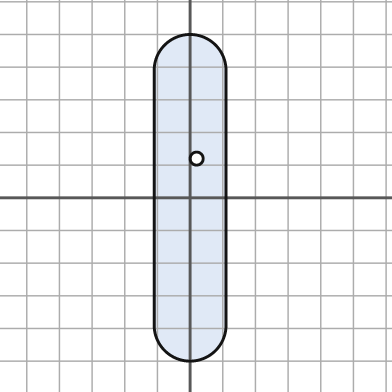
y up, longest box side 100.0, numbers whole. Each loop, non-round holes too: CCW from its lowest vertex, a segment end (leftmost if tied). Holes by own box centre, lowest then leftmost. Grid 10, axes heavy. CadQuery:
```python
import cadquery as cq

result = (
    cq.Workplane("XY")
    .moveTo(-11.0, -39.0)
    .threePointArc((0.0, -50.0), (11.0, -39.0))
    .lineTo(11.0, 39.0)
    .threePointArc((0.0, 50.0), (-11.0, 39.0))
    .close()
    .moveTo(2.0, 12.0)
    .circle(2.0)
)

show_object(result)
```